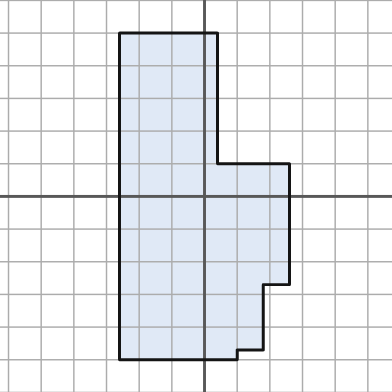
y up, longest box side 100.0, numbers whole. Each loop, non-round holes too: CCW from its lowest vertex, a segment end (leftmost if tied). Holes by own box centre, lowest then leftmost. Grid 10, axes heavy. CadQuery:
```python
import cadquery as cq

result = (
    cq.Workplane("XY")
    .moveTo(-26.0, -50.0)
    .lineTo(10.0, -50.0)
    .lineTo(10.0, -47.0)
    .lineTo(18.0, -47.0)
    .lineTo(18.0, -27.0)
    .lineTo(26.0, -27.0)
    .lineTo(26.0, 10.0)
    .lineTo(4.0, 10.0)
    .lineTo(4.0, 50.0)
    .lineTo(-26.0, 50.0)
    .close()
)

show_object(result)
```